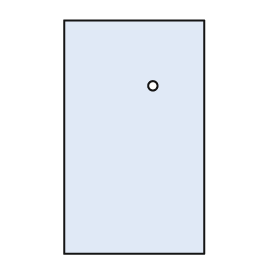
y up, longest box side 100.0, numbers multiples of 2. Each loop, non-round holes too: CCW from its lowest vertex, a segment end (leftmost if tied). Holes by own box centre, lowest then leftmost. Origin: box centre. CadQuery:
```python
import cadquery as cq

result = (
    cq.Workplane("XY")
    .moveTo(-30.0, -50.0)
    .lineTo(30.0, -50.0)
    .lineTo(30.0, 50.0)
    .lineTo(-30.0, 50.0)
    .close()
    .moveTo(8.0, 22.0)
    .circle(2.0)
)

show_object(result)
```